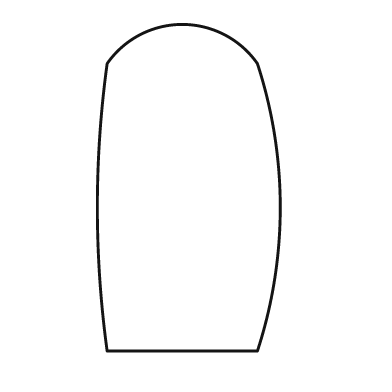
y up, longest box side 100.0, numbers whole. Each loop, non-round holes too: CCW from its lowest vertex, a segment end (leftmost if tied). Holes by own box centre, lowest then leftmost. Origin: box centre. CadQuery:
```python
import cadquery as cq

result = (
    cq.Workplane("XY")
    .moveTo(-25.0, -50.0)
    .lineTo(21.0, -50.0)
    .threePointArc((28.0, -6.0), (21.0, 38.0))
    .threePointArc((-2.0, 50.0), (-25.0, 38.0))
    .threePointArc((-28.0, -6.0), (-25.0, -50.0))
    .close()
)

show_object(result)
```